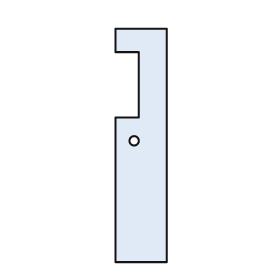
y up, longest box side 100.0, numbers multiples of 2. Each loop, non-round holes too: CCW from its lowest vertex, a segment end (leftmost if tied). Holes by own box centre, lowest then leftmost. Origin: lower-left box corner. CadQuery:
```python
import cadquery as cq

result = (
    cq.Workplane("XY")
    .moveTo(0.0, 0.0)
    .lineTo(22.0, 0.0)
    .lineTo(22.0, 100.0)
    .lineTo(0.0, 100.0)
    .lineTo(0.0, 90.0)
    .lineTo(10.0, 90.0)
    .lineTo(10.0, 62.0)
    .lineTo(0.0, 62.0)
    .close()
    .moveTo(8.0, 52.0)
    .circle(2.0)
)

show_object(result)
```